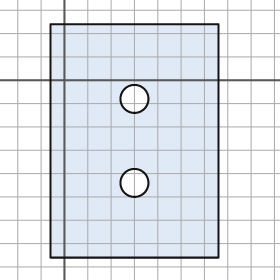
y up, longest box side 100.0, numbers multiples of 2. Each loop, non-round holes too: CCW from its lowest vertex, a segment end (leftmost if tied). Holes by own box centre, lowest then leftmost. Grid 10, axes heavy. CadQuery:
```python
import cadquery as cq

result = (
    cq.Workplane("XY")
    .moveTo(-6.0, -76.0)
    .lineTo(66.0, -76.0)
    .lineTo(66.0, 24.0)
    .lineTo(-6.0, 24.0)
    .close()
    .moveTo(30.0, -44.0)
    .circle(6.0)
    .moveTo(30.0, -8.0)
    .circle(6.0)
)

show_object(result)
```